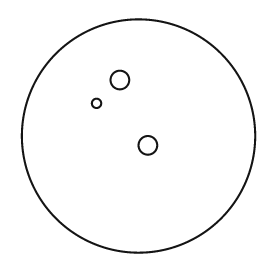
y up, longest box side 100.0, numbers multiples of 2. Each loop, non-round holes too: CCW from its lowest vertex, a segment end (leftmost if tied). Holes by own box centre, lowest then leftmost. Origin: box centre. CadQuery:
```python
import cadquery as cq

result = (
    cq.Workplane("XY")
    .moveTo(0.0, 0.0)
    .circle(50.0)
    .moveTo(4.0, -4.0)
    .circle(4.0)
    .moveTo(-18.0, 14.0)
    .circle(2.0)
    .moveTo(-8.0, 24.0)
    .circle(4.0)
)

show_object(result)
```